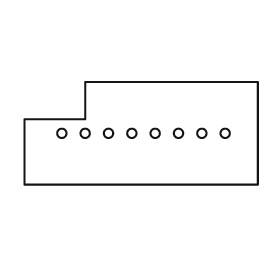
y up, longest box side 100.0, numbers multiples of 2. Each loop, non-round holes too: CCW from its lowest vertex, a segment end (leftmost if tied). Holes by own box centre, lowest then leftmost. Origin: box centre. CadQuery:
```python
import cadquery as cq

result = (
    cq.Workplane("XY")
    .moveTo(-50.0, -22.0)
    .lineTo(50.0, -22.0)
    .lineTo(50.0, 22.0)
    .lineTo(-24.0, 22.0)
    .lineTo(-24.0, 6.0)
    .lineTo(-50.0, 6.0)
    .close()
    .moveTo(-34.0, 0.0)
    .circle(2.0)
    .moveTo(-24.0, 0.0)
    .circle(2.0)
    .moveTo(-14.0, 0.0)
    .circle(2.0)
    .moveTo(-4.0, 0.0)
    .circle(2.0)
    .moveTo(6.0, 0.0)
    .circle(2.0)
    .moveTo(16.0, 0.0)
    .circle(2.0)
    .moveTo(26.0, 0.0)
    .circle(2.0)
    .moveTo(36.0, 0.0)
    .circle(2.0)
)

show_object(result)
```